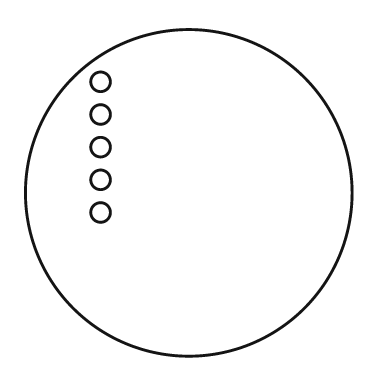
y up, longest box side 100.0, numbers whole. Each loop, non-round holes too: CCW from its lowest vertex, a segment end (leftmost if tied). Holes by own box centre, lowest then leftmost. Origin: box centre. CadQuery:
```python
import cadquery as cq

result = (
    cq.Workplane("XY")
    .moveTo(0.0, 0.0)
    .circle(50.0)
    .moveTo(-27.0, -6.0)
    .circle(3.0)
    .moveTo(-27.0, 4.0)
    .circle(3.0)
    .moveTo(-27.0, 14.0)
    .circle(3.0)
    .moveTo(-27.0, 24.0)
    .circle(3.0)
    .moveTo(-27.0, 34.0)
    .circle(3.0)
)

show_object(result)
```